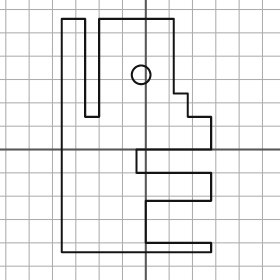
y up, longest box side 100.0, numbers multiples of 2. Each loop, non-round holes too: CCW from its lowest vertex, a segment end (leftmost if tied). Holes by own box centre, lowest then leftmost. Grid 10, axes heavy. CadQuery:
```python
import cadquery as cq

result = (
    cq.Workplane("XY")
    .moveTo(-36.0, -44.0)
    .lineTo(28.0, -44.0)
    .lineTo(28.0, -40.0)
    .lineTo(0.0, -40.0)
    .lineTo(0.0, -22.0)
    .lineTo(28.0, -22.0)
    .lineTo(28.0, -10.0)
    .lineTo(-4.0, -10.0)
    .lineTo(-4.0, 0.0)
    .lineTo(28.0, 0.0)
    .lineTo(28.0, 14.0)
    .lineTo(18.0, 14.0)
    .lineTo(18.0, 24.0)
    .lineTo(12.0, 24.0)
    .lineTo(12.0, 56.0)
    .lineTo(-20.0, 56.0)
    .lineTo(-20.0, 14.0)
    .lineTo(-26.0, 14.0)
    .lineTo(-26.0, 56.0)
    .lineTo(-36.0, 56.0)
    .close()
    .moveTo(-2.0, 32.0)
    .circle(4.0)
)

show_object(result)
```